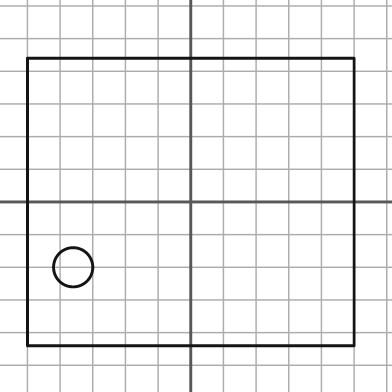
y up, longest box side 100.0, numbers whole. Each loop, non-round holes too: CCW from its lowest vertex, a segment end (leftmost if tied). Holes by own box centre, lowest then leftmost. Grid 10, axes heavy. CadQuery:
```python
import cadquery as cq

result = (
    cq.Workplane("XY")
    .moveTo(-50.0, -44.0)
    .lineTo(50.0, -44.0)
    .lineTo(50.0, 44.0)
    .lineTo(-50.0, 44.0)
    .close()
    .moveTo(-36.0, -20.0)
    .circle(6.0)
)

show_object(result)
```